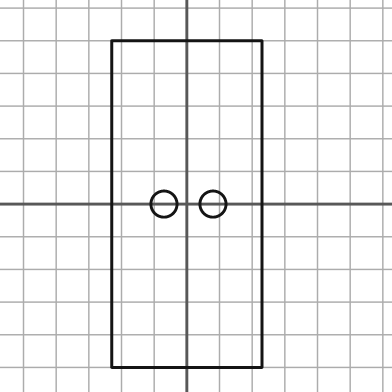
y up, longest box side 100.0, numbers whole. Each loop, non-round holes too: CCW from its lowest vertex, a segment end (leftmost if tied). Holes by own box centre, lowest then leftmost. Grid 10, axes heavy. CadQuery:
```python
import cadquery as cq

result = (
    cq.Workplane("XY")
    .moveTo(-23.0, -50.0)
    .lineTo(23.0, -50.0)
    .lineTo(23.0, 50.0)
    .lineTo(-23.0, 50.0)
    .close()
    .moveTo(-7.0, 0.0)
    .circle(4.0)
    .moveTo(8.0, 0.0)
    .circle(4.0)
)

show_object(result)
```